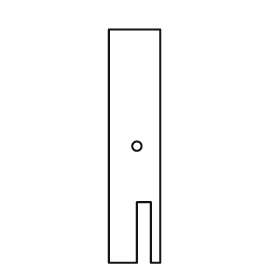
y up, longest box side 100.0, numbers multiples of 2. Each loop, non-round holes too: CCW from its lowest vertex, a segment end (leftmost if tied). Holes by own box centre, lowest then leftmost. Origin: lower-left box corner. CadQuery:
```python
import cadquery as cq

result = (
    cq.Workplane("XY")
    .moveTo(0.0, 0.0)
    .lineTo(12.0, 0.0)
    .lineTo(12.0, 26.0)
    .lineTo(18.0, 26.0)
    .lineTo(18.0, 0.0)
    .lineTo(22.0, 0.0)
    .lineTo(22.0, 100.0)
    .lineTo(0.0, 100.0)
    .close()
    .moveTo(12.0, 50.0)
    .circle(2.0)
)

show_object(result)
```